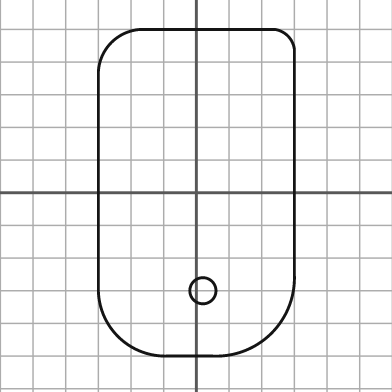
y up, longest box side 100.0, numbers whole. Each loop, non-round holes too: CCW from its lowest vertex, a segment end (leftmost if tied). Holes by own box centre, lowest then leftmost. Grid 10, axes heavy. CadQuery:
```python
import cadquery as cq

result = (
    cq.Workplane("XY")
    .moveTo(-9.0, -50.0)
    .lineTo(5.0, -50.0)
    .threePointArc((23.0, -43.0), (30.0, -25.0))
    .lineTo(30.0, 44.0)
    .threePointArc((28.0, 48.0), (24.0, 50.0))
    .lineTo(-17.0, 50.0)
    .threePointArc((-26.0, 46.0), (-30.0, 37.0))
    .lineTo(-30.0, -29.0)
    .threePointArc((-24.0, -44.0), (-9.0, -50.0))
    .close()
    .moveTo(2.0, -30.0)
    .circle(4.0)
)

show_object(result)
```